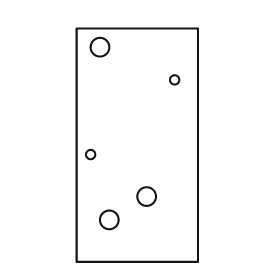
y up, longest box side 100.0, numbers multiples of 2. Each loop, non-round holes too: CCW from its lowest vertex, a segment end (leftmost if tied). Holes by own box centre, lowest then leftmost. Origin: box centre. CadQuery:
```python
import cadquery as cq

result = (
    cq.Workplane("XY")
    .moveTo(-26.0, -50.0)
    .lineTo(26.0, -50.0)
    .lineTo(26.0, 50.0)
    .lineTo(-26.0, 50.0)
    .close()
    .moveTo(-12.0, -32.0)
    .circle(4.0)
    .moveTo(4.0, -22.0)
    .circle(4.0)
    .moveTo(-20.0, -4.0)
    .circle(2.0)
    .moveTo(16.0, 28.0)
    .circle(2.0)
    .moveTo(-16.0, 42.0)
    .circle(4.0)
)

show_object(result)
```